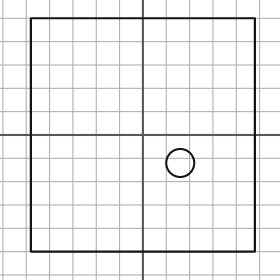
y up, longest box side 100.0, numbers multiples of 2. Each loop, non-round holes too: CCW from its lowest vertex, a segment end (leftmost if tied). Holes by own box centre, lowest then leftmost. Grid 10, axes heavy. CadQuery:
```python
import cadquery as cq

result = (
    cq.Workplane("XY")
    .moveTo(-48.0, -50.0)
    .lineTo(48.0, -50.0)
    .lineTo(48.0, 50.0)
    .lineTo(-48.0, 50.0)
    .close()
    .moveTo(16.0, -12.0)
    .circle(6.0)
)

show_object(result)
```